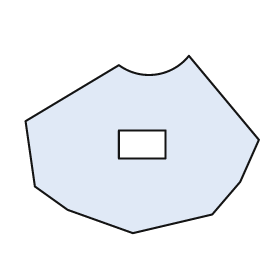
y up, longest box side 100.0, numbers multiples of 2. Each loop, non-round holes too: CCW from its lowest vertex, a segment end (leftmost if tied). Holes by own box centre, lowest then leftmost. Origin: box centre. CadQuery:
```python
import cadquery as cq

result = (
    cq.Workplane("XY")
    .moveTo(-4.0, -38.0)
    .lineTo(30.0, -30.0)
    .lineTo(42.0, -16.0)
    .lineTo(50.0, 2.0)
    .lineTo(20.0, 38.0)
    .threePointArc((6.0, 30.0), (-10.0, 34.0))
    .lineTo(-50.0, 10.0)
    .lineTo(-46.0, -18.0)
    .lineTo(-32.0, -28.0)
    .close()
    .moveTo(-10.0, -6.0)
    .lineTo(10.0, -6.0)
    .lineTo(10.0, 6.0)
    .lineTo(-10.0, 6.0)
    .close()
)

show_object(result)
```